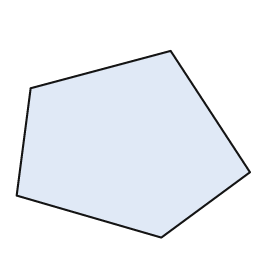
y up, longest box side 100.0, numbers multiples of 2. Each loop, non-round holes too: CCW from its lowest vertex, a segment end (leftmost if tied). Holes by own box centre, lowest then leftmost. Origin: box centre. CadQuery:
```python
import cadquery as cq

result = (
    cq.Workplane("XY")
    .moveTo(12.0, -40.0)
    .lineTo(50.0, -12.0)
    .lineTo(16.0, 40.0)
    .lineTo(-44.0, 24.0)
    .lineTo(-50.0, -22.0)
    .close()
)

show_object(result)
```